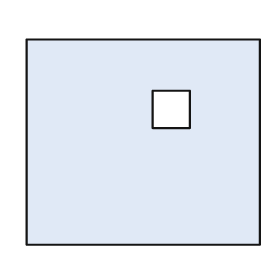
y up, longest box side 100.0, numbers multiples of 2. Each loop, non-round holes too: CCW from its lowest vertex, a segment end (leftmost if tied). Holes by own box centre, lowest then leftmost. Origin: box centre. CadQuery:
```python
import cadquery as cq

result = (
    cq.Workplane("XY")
    .moveTo(-50.0, -44.0)
    .lineTo(50.0, -44.0)
    .lineTo(50.0, 44.0)
    .lineTo(-50.0, 44.0)
    .close()
    .moveTo(4.0, 6.0)
    .lineTo(20.0, 6.0)
    .lineTo(20.0, 22.0)
    .lineTo(4.0, 22.0)
    .close()
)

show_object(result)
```